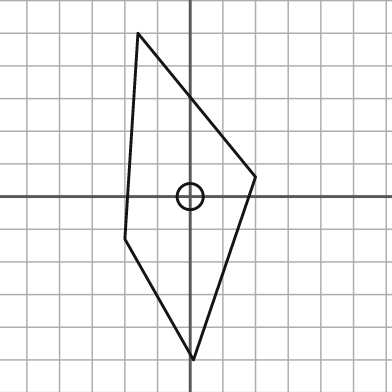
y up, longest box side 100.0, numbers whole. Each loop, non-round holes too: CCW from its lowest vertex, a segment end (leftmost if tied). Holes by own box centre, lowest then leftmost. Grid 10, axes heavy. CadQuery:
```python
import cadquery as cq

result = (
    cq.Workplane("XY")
    .moveTo(1.0, -50.0)
    .lineTo(20.0, 6.0)
    .lineTo(-16.0, 50.0)
    .lineTo(-20.0, -13.0)
    .close()
    .moveTo(0.0, 0.0)
    .circle(4.0)
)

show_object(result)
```